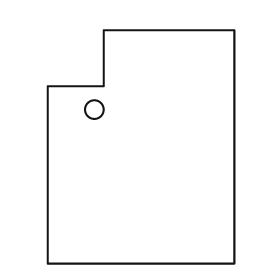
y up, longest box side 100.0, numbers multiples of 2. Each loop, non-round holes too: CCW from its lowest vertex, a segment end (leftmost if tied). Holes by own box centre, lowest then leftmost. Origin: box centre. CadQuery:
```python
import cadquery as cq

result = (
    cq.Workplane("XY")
    .moveTo(-40.0, -50.0)
    .lineTo(40.0, -50.0)
    .lineTo(40.0, 50.0)
    .lineTo(-16.0, 50.0)
    .lineTo(-16.0, 26.0)
    .lineTo(-40.0, 26.0)
    .close()
    .moveTo(-20.0, 16.0)
    .circle(4.0)
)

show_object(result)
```